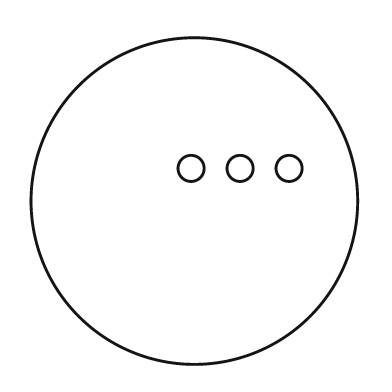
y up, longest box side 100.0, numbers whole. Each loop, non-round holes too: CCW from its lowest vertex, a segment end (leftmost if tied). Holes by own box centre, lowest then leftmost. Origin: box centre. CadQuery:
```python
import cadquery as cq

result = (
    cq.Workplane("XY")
    .moveTo(0.0, 0.0)
    .circle(50.0)
    .moveTo(-1.0, 10.0)
    .circle(4.0)
    .moveTo(14.0, 10.0)
    .circle(4.0)
    .moveTo(29.0, 10.0)
    .circle(4.0)
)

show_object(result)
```